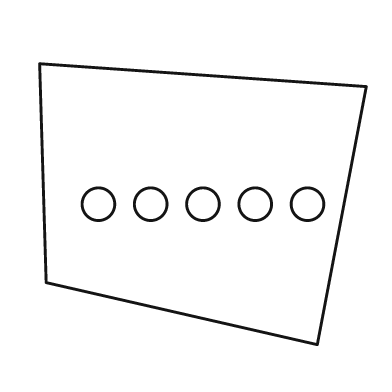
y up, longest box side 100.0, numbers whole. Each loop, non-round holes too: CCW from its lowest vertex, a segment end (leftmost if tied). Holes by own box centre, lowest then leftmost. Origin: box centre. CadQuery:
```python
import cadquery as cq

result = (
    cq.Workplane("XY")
    .moveTo(35.0, -43.0)
    .lineTo(50.0, 36.0)
    .lineTo(-50.0, 43.0)
    .lineTo(-48.0, -24.0)
    .close()
    .moveTo(-32.0, 0.0)
    .circle(5.0)
    .moveTo(-16.0, 0.0)
    .circle(5.0)
    .moveTo(0.0, 0.0)
    .circle(5.0)
    .moveTo(16.0, 0.0)
    .circle(5.0)
    .moveTo(32.0, 0.0)
    .circle(5.0)
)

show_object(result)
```